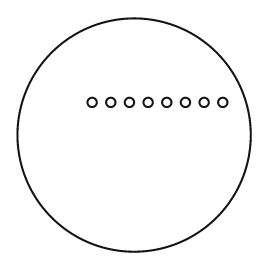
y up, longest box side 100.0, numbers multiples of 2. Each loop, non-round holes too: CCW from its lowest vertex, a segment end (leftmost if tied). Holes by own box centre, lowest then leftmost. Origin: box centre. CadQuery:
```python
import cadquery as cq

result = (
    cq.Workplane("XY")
    .moveTo(0.0, 0.0)
    .circle(50.0)
    .moveTo(-18.0, 14.0)
    .circle(2.0)
    .moveTo(-10.0, 14.0)
    .circle(2.0)
    .moveTo(-2.0, 14.0)
    .circle(2.0)
    .moveTo(6.0, 14.0)
    .circle(2.0)
    .moveTo(14.0, 14.0)
    .circle(2.0)
    .moveTo(22.0, 14.0)
    .circle(2.0)
    .moveTo(30.0, 14.0)
    .circle(2.0)
    .moveTo(38.0, 14.0)
    .circle(2.0)
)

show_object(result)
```